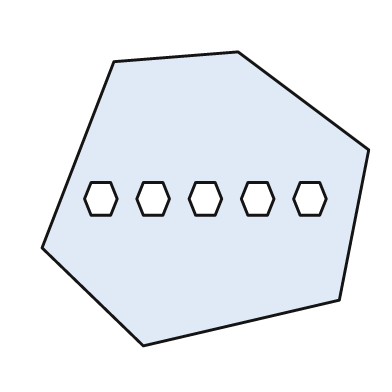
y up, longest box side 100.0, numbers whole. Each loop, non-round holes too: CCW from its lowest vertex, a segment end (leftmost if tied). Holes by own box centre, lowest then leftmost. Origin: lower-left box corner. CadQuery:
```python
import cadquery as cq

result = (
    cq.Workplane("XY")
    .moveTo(31.0, 0.0)
    .lineTo(91.0, 14.0)
    .lineTo(100.0, 60.0)
    .lineTo(60.0, 90.0)
    .lineTo(22.0, 87.0)
    .lineTo(0.0, 30.0)
    .close()
    .moveTo(15.0, 40.0)
    .lineTo(21.0, 40.0)
    .lineTo(23.0, 45.0)
    .lineTo(21.0, 50.0)
    .lineTo(15.0, 50.0)
    .lineTo(13.0, 45.0)
    .close()
    .moveTo(31.0, 40.0)
    .lineTo(37.0, 40.0)
    .lineTo(39.0, 45.0)
    .lineTo(37.0, 50.0)
    .lineTo(31.0, 50.0)
    .lineTo(29.0, 45.0)
    .close()
    .moveTo(47.0, 40.0)
    .lineTo(53.0, 40.0)
    .lineTo(55.0, 45.0)
    .lineTo(53.0, 50.0)
    .lineTo(47.0, 50.0)
    .lineTo(45.0, 45.0)
    .close()
    .moveTo(63.0, 40.0)
    .lineTo(69.0, 40.0)
    .lineTo(71.0, 45.0)
    .lineTo(69.0, 50.0)
    .lineTo(63.0, 50.0)
    .lineTo(61.0, 45.0)
    .close()
    .moveTo(79.0, 40.0)
    .lineTo(85.0, 40.0)
    .lineTo(87.0, 45.0)
    .lineTo(85.0, 50.0)
    .lineTo(79.0, 50.0)
    .lineTo(77.0, 45.0)
    .close()
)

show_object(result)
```